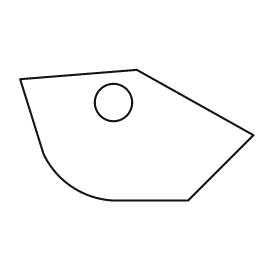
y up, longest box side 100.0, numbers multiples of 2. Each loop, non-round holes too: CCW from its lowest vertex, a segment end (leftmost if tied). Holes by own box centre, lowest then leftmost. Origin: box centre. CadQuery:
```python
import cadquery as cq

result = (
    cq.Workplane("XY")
    .moveTo(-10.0, -28.0)
    .lineTo(22.0, -28.0)
    .lineTo(50.0, 0.0)
    .lineTo(0.0, 28.0)
    .lineTo(-50.0, 24.0)
    .lineTo(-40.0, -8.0)
    .threePointArc((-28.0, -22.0), (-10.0, -28.0))
    .close()
    .moveTo(-10.0, 14.0)
    .circle(8.0)
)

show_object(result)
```